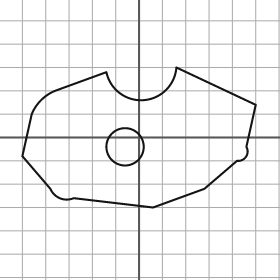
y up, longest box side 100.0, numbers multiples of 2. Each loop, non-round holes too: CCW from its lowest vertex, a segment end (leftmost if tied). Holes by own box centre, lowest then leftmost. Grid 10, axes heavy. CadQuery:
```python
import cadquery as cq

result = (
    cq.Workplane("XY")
    .moveTo(6.0, -30.0)
    .lineTo(28.0, -22.0)
    .lineTo(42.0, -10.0)
    .threePointArc((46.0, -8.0), (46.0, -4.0))
    .lineTo(50.0, 14.0)
    .lineTo(16.0, 30.0)
    .threePointArc((2.0, 16.0), (-14.0, 28.0))
    .lineTo(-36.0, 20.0)
    .threePointArc((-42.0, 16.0), (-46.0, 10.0))
    .lineTo(-50.0, -8.0)
    .lineTo(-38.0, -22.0)
    .threePointArc((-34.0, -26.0), (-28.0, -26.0))
    .close()
    .moveTo(-6.0, -4.0)
    .circle(8.0)
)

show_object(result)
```